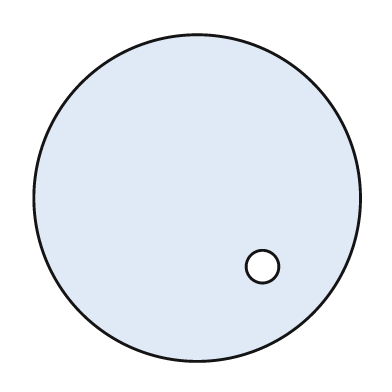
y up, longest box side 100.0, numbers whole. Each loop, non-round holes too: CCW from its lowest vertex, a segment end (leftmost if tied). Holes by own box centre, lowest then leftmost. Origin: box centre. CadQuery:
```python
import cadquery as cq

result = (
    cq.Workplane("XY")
    .moveTo(0.0, 0.0)
    .circle(50.0)
    .moveTo(20.0, -21.0)
    .circle(5.0)
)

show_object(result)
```